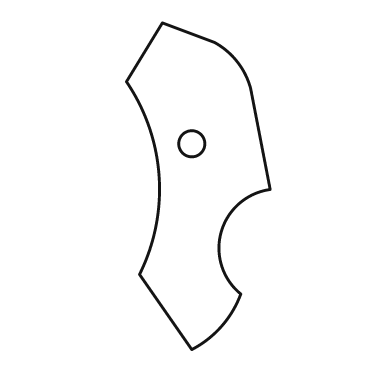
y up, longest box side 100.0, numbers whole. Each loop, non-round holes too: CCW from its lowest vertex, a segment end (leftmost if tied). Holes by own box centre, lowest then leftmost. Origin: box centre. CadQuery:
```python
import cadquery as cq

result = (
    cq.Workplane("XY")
    .moveTo(-2.0, -50.0)
    .threePointArc((7.0, -43.0), (13.0, -33.0))
    .threePointArc((7.0, -14.0), (22.0, -1.0))
    .lineTo(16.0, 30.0)
    .threePointArc((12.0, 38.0), (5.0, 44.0))
    .lineTo(-11.0, 50.0)
    .lineTo(-22.0, 32.0)
    .threePointArc((-12.0, 3.0), (-18.0, -27.0))
    .close()
    .moveTo(-2.0, 13.0)
    .circle(4.0)
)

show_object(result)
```